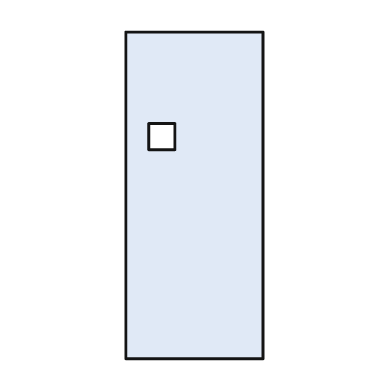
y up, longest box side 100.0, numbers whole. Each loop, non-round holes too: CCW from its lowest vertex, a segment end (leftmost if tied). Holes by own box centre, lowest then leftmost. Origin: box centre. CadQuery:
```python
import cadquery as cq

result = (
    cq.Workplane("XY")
    .moveTo(-21.0, -50.0)
    .lineTo(21.0, -50.0)
    .lineTo(21.0, 50.0)
    .lineTo(-21.0, 50.0)
    .close()
    .moveTo(-14.0, 14.0)
    .lineTo(-6.0, 14.0)
    .lineTo(-6.0, 22.0)
    .lineTo(-14.0, 22.0)
    .close()
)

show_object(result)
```